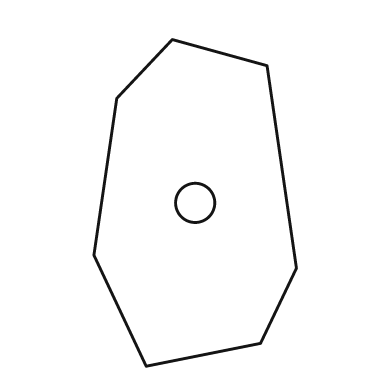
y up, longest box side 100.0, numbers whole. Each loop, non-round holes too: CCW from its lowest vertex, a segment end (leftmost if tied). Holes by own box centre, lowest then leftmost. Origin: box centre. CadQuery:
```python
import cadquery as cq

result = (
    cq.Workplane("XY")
    .moveTo(-15.0, -50.0)
    .lineTo(20.0, -43.0)
    .lineTo(31.0, -20.0)
    .lineTo(22.0, 42.0)
    .lineTo(-7.0, 50.0)
    .lineTo(-24.0, 32.0)
    .lineTo(-31.0, -16.0)
    .close()
    .moveTo(0.0, 0.0)
    .circle(6.0)
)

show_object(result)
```